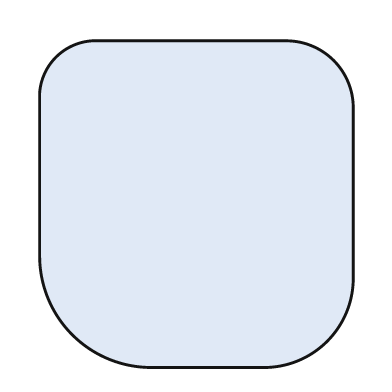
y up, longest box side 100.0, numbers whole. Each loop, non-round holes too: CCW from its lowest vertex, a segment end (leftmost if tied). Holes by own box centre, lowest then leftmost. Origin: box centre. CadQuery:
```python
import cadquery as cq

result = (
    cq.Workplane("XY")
    .moveTo(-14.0, -50.0)
    .lineTo(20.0, -50.0)
    .threePointArc((40.0, -42.0), (48.0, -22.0))
    .lineTo(48.0, 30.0)
    .threePointArc((42.0, 44.0), (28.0, 50.0))
    .lineTo(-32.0, 50.0)
    .threePointArc((-43.0, 45.0), (-48.0, 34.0))
    .lineTo(-48.0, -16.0)
    .threePointArc((-38.0, -40.0), (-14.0, -50.0))
    .close()
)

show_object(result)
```